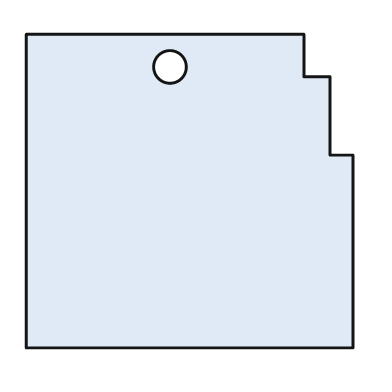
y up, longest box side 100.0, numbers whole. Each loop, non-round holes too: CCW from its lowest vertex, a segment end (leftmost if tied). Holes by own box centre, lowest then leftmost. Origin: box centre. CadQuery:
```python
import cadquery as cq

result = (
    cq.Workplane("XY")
    .moveTo(-50.0, -48.0)
    .lineTo(50.0, -48.0)
    .lineTo(50.0, 11.0)
    .lineTo(43.0, 11.0)
    .lineTo(43.0, 35.0)
    .lineTo(35.0, 35.0)
    .lineTo(35.0, 48.0)
    .lineTo(-50.0, 48.0)
    .close()
    .moveTo(-6.0, 38.0)
    .circle(5.0)
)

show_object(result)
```